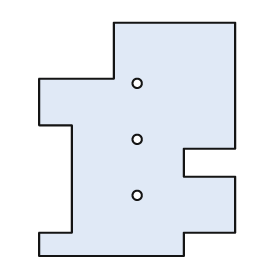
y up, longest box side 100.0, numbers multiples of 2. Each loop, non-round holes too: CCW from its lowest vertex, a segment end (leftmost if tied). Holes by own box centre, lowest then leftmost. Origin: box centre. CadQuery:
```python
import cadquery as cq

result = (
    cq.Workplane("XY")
    .moveTo(-42.0, -50.0)
    .lineTo(20.0, -50.0)
    .lineTo(20.0, -40.0)
    .lineTo(42.0, -40.0)
    .lineTo(42.0, -16.0)
    .lineTo(20.0, -16.0)
    .lineTo(20.0, -4.0)
    .lineTo(42.0, -4.0)
    .lineTo(42.0, 50.0)
    .lineTo(-10.0, 50.0)
    .lineTo(-10.0, 26.0)
    .lineTo(-42.0, 26.0)
    .lineTo(-42.0, 6.0)
    .lineTo(-28.0, 6.0)
    .lineTo(-28.0, -40.0)
    .lineTo(-42.0, -40.0)
    .close()
    .moveTo(0.0, -24.0)
    .circle(2.0)
    .moveTo(0.0, 0.0)
    .circle(2.0)
    .moveTo(0.0, 24.0)
    .circle(2.0)
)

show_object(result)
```